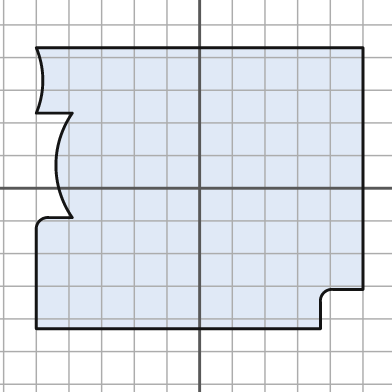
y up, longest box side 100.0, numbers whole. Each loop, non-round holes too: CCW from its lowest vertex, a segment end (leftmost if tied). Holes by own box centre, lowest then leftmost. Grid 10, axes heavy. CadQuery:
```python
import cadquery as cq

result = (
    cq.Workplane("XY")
    .moveTo(-50.0, -43.0)
    .lineTo(37.0, -43.0)
    .lineTo(37.0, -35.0)
    .threePointArc((38.0, -32.0), (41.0, -31.0))
    .lineTo(50.0, -31.0)
    .lineTo(50.0, 43.0)
    .lineTo(-50.0, 43.0)
    .threePointArc((-48.0, 33.0), (-50.0, 23.0))
    .lineTo(-39.0, 23.0)
    .threePointArc((-44.0, 7.0), (-39.0, -9.0))
    .lineTo(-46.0, -9.0)
    .threePointArc((-49.0, -10.0), (-50.0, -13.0))
    .close()
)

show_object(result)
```